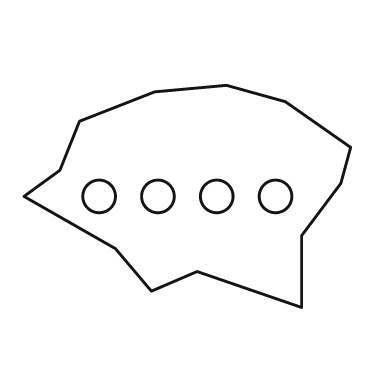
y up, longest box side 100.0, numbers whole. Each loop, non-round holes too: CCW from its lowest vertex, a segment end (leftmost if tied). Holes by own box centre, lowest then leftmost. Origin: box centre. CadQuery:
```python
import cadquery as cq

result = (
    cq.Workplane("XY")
    .moveTo(35.0, -34.0)
    .lineTo(35.0, -12.0)
    .lineTo(47.0, 4.0)
    .lineTo(50.0, 15.0)
    .lineTo(30.0, 29.0)
    .lineTo(12.0, 34.0)
    .lineTo(-10.0, 32.0)
    .lineTo(-33.0, 23.0)
    .lineTo(-39.0, 8.0)
    .lineTo(-50.0, 0.0)
    .lineTo(-22.0, -16.0)
    .lineTo(-11.0, -29.0)
    .lineTo(3.0, -23.0)
    .close()
    .moveTo(-27.0, 0.0)
    .circle(5.0)
    .moveTo(-9.0, 0.0)
    .circle(5.0)
    .moveTo(9.0, 0.0)
    .circle(5.0)
    .moveTo(27.0, 0.0)
    .circle(5.0)
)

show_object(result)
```